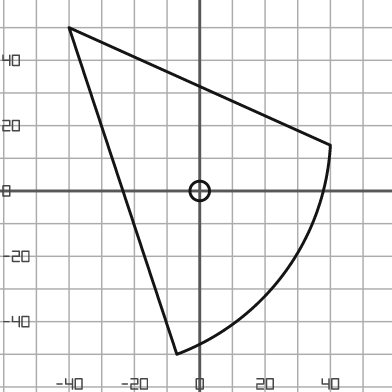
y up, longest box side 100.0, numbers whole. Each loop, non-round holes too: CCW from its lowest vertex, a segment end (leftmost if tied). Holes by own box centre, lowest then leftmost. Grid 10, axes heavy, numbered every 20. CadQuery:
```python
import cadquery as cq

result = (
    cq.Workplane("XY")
    .moveTo(-7.0, -50.0)
    .threePointArc((26.0, -25.0), (40.0, 14.0))
    .lineTo(-40.0, 50.0)
    .close()
    .moveTo(0.0, 0.0)
    .circle(3.0)
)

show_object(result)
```